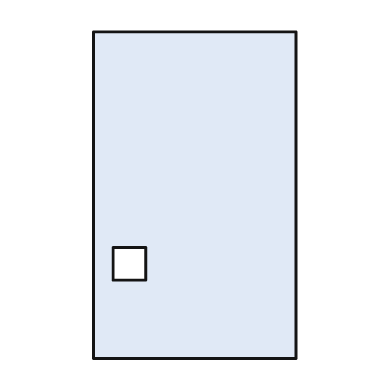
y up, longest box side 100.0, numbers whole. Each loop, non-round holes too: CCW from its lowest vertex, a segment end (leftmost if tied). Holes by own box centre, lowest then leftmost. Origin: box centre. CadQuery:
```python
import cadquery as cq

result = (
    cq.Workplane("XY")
    .moveTo(-31.0, -50.0)
    .lineTo(31.0, -50.0)
    .lineTo(31.0, 50.0)
    .lineTo(-31.0, 50.0)
    .close()
    .moveTo(-25.0, -26.0)
    .lineTo(-15.0, -26.0)
    .lineTo(-15.0, -16.0)
    .lineTo(-25.0, -16.0)
    .close()
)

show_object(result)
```